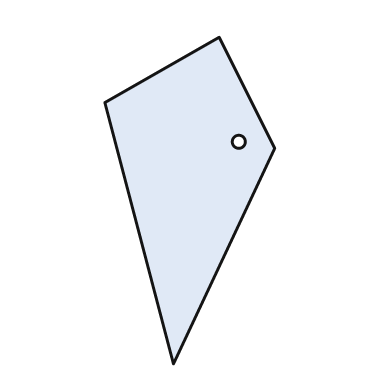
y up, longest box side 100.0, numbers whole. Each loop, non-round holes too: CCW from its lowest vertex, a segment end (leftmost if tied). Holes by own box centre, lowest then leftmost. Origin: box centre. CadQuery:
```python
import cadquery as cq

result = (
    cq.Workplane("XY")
    .moveTo(-5.0, -50.0)
    .lineTo(26.0, 16.0)
    .lineTo(9.0, 50.0)
    .lineTo(-26.0, 30.0)
    .close()
    .moveTo(15.0, 18.0)
    .circle(2.0)
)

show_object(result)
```